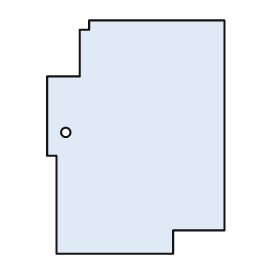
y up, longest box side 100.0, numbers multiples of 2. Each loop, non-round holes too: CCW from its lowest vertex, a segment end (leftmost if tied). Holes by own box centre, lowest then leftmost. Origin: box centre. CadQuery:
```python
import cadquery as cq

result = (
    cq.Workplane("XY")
    .moveTo(-34.0, -50.0)
    .lineTo(16.0, -50.0)
    .lineTo(16.0, -40.0)
    .lineTo(38.0, -40.0)
    .lineTo(38.0, 50.0)
    .lineTo(-20.0, 50.0)
    .lineTo(-20.0, 46.0)
    .lineTo(-24.0, 46.0)
    .lineTo(-24.0, 26.0)
    .lineTo(-38.0, 26.0)
    .lineTo(-38.0, -8.0)
    .lineTo(-34.0, -8.0)
    .close()
    .moveTo(-30.0, 2.0)
    .circle(2.0)
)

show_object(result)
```